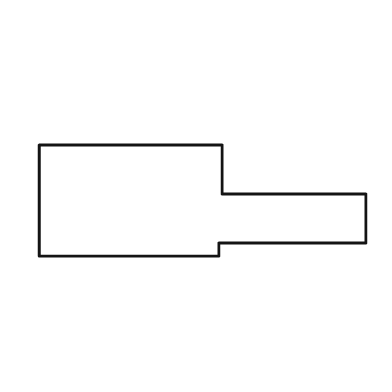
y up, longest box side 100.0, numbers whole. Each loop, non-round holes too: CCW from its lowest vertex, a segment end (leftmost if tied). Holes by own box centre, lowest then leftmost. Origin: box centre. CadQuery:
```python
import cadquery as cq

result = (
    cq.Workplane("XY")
    .moveTo(-50.0, -17.0)
    .lineTo(5.0, -17.0)
    .lineTo(5.0, -13.0)
    .lineTo(50.0, -13.0)
    .lineTo(50.0, 2.0)
    .lineTo(6.0, 2.0)
    .lineTo(6.0, 17.0)
    .lineTo(-50.0, 17.0)
    .close()
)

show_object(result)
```